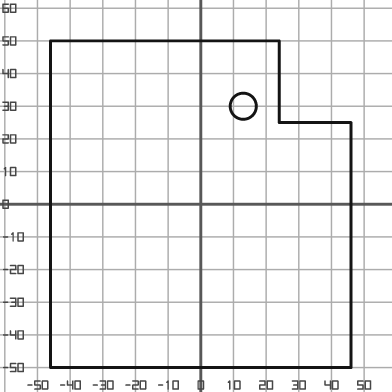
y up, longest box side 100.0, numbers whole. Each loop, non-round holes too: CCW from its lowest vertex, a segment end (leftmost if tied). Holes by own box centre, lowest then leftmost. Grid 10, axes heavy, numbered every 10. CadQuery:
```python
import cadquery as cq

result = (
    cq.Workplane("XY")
    .moveTo(-46.0, -50.0)
    .lineTo(46.0, -50.0)
    .lineTo(46.0, 25.0)
    .lineTo(24.0, 25.0)
    .lineTo(24.0, 50.0)
    .lineTo(-46.0, 50.0)
    .close()
    .moveTo(13.0, 30.0)
    .circle(4.0)
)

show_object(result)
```